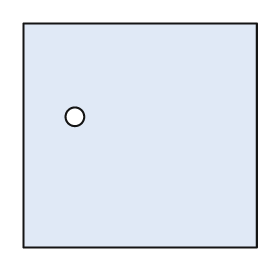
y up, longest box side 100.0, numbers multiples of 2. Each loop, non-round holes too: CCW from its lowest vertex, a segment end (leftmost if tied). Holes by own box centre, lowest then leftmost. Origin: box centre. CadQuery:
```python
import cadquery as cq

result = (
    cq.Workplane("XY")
    .moveTo(-50.0, -48.0)
    .lineTo(50.0, -48.0)
    .lineTo(50.0, 48.0)
    .lineTo(-50.0, 48.0)
    .close()
    .moveTo(-28.0, 8.0)
    .circle(4.0)
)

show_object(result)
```